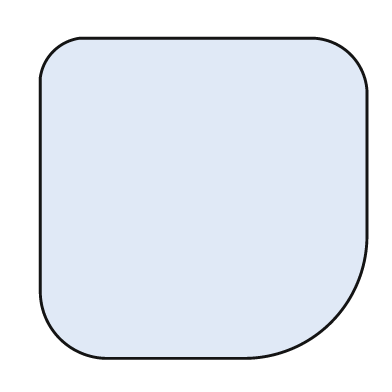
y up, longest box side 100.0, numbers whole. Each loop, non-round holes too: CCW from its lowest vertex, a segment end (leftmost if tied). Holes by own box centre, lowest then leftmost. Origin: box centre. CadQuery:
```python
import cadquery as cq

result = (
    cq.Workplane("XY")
    .moveTo(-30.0, -49.0)
    .lineTo(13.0, -49.0)
    .threePointArc((39.0, -38.0), (50.0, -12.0))
    .lineTo(50.0, 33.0)
    .threePointArc((45.0, 44.0), (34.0, 49.0))
    .lineTo(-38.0, 49.0)
    .threePointArc((-46.0, 45.0), (-50.0, 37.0))
    .lineTo(-50.0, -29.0)
    .threePointArc((-44.0, -43.0), (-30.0, -49.0))
    .close()
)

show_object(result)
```